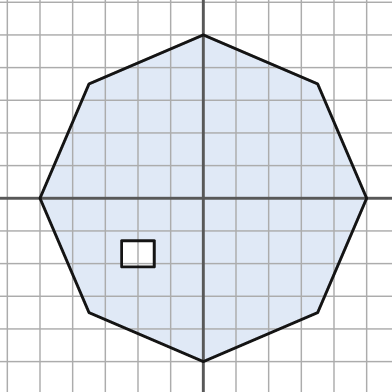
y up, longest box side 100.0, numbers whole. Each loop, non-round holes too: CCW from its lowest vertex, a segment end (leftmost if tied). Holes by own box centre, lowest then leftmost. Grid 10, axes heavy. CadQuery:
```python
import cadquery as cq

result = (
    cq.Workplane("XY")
    .moveTo(0.0, -50.0)
    .lineTo(35.0, -35.0)
    .lineTo(50.0, 0.0)
    .lineTo(35.0, 35.0)
    .lineTo(0.0, 50.0)
    .lineTo(-35.0, 35.0)
    .lineTo(-50.0, 0.0)
    .lineTo(-35.0, -35.0)
    .close()
    .moveTo(-25.0, -21.0)
    .lineTo(-15.0, -21.0)
    .lineTo(-15.0, -13.0)
    .lineTo(-25.0, -13.0)
    .close()
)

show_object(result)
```